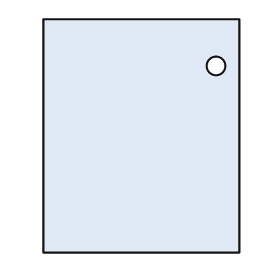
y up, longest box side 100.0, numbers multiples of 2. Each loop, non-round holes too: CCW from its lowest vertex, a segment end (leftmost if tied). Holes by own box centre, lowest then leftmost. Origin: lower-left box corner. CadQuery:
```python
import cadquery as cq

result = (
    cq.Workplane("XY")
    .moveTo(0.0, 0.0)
    .lineTo(84.0, 0.0)
    .lineTo(84.0, 100.0)
    .lineTo(0.0, 100.0)
    .close()
    .moveTo(74.0, 80.0)
    .circle(4.0)
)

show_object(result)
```